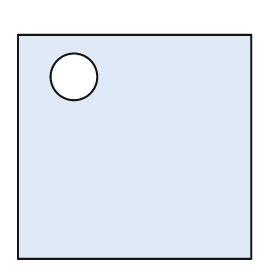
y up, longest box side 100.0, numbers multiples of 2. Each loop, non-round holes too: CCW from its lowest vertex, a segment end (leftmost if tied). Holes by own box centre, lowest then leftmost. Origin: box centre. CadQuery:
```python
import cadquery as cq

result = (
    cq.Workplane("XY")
    .moveTo(-50.0, -48.0)
    .lineTo(50.0, -48.0)
    .lineTo(50.0, 48.0)
    .lineTo(-50.0, 48.0)
    .close()
    .moveTo(-26.0, 30.0)
    .circle(10.0)
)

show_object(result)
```